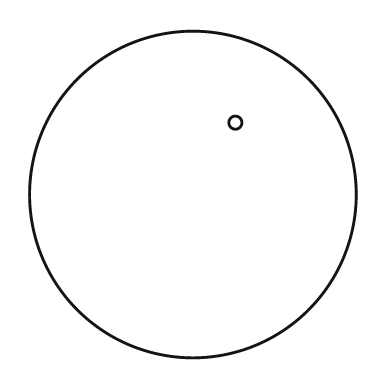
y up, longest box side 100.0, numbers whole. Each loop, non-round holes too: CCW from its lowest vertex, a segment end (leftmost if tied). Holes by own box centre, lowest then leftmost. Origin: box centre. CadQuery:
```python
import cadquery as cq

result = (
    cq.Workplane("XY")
    .moveTo(0.0, 0.0)
    .circle(50.0)
    .moveTo(13.0, 22.0)
    .circle(2.0)
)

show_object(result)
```